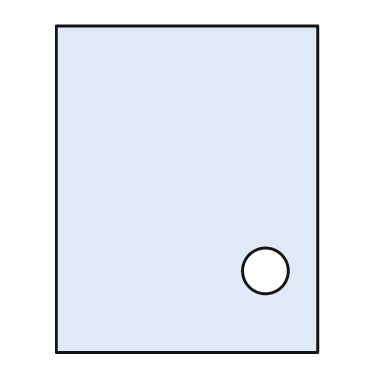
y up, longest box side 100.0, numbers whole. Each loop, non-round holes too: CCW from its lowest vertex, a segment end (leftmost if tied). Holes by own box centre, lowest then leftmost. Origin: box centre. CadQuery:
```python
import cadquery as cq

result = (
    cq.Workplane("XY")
    .moveTo(-40.0, -50.0)
    .lineTo(40.0, -50.0)
    .lineTo(40.0, 50.0)
    .lineTo(-40.0, 50.0)
    .close()
    .moveTo(24.0, -25.0)
    .circle(7.0)
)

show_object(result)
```